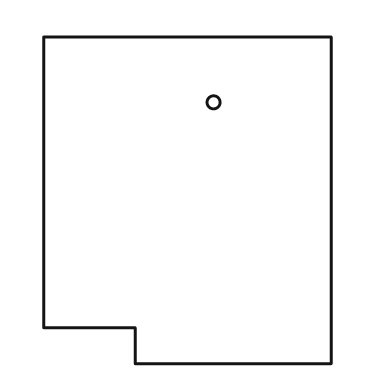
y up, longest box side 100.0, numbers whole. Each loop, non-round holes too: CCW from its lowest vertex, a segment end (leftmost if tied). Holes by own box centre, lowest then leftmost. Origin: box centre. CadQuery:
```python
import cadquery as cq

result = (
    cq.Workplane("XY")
    .moveTo(-16.0, -50.0)
    .lineTo(44.0, -50.0)
    .lineTo(44.0, 50.0)
    .lineTo(-44.0, 50.0)
    .lineTo(-44.0, -39.0)
    .lineTo(-16.0, -39.0)
    .close()
    .moveTo(8.0, 30.0)
    .circle(2.0)
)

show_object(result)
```